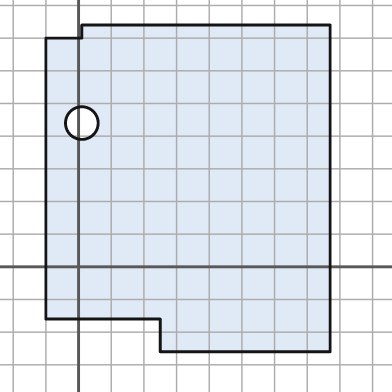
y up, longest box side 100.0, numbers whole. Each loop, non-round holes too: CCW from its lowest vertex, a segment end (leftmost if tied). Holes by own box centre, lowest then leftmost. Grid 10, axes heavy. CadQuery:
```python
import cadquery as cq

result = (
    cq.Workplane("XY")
    .moveTo(25.0, -26.0)
    .lineTo(77.0, -26.0)
    .lineTo(77.0, 74.0)
    .lineTo(1.0, 74.0)
    .lineTo(1.0, 70.0)
    .lineTo(-10.0, 70.0)
    .lineTo(-10.0, -16.0)
    .lineTo(25.0, -16.0)
    .close()
    .moveTo(1.0, 44.0)
    .circle(5.0)
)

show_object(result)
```